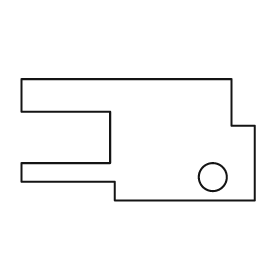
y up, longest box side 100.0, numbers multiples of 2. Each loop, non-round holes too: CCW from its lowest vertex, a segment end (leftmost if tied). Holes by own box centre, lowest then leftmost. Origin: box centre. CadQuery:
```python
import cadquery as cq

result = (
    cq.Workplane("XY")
    .moveTo(-10.0, -26.0)
    .lineTo(50.0, -26.0)
    .lineTo(50.0, 6.0)
    .lineTo(40.0, 6.0)
    .lineTo(40.0, 26.0)
    .lineTo(-50.0, 26.0)
    .lineTo(-50.0, 12.0)
    .lineTo(-12.0, 12.0)
    .lineTo(-12.0, -10.0)
    .lineTo(-50.0, -10.0)
    .lineTo(-50.0, -18.0)
    .lineTo(-10.0, -18.0)
    .close()
    .moveTo(32.0, -16.0)
    .circle(6.0)
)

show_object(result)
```